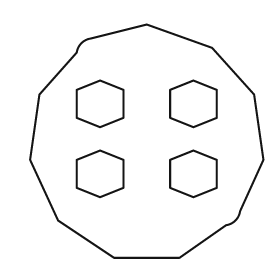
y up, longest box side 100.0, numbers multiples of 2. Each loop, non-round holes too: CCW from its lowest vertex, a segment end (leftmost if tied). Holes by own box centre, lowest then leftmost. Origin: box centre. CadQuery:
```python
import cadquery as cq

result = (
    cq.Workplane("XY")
    .moveTo(-14.0, -50.0)
    .lineTo(14.0, -50.0)
    .lineTo(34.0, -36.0)
    .threePointArc((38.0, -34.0), (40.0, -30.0))
    .lineTo(50.0, -8.0)
    .lineTo(46.0, 20.0)
    .lineTo(28.0, 40.0)
    .lineTo(0.0, 50.0)
    .lineTo(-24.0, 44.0)
    .threePointArc((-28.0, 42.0), (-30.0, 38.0))
    .lineTo(-46.0, 20.0)
    .lineTo(-50.0, -8.0)
    .lineTo(-38.0, -34.0)
    .close()
    .moveTo(-20.0, -24.0)
    .lineTo(-10.0, -20.0)
    .lineTo(-10.0, -8.0)
    .lineTo(-20.0, -4.0)
    .lineTo(-30.0, -8.0)
    .lineTo(-30.0, -20.0)
    .close()
    .moveTo(20.0, -24.0)
    .lineTo(30.0, -20.0)
    .lineTo(30.0, -8.0)
    .lineTo(20.0, -4.0)
    .lineTo(10.0, -8.0)
    .lineTo(10.0, -20.0)
    .close()
    .moveTo(-20.0, 6.0)
    .lineTo(-10.0, 10.0)
    .lineTo(-10.0, 22.0)
    .lineTo(-20.0, 26.0)
    .lineTo(-30.0, 22.0)
    .lineTo(-30.0, 10.0)
    .close()
    .moveTo(20.0, 6.0)
    .lineTo(30.0, 10.0)
    .lineTo(30.0, 22.0)
    .lineTo(20.0, 26.0)
    .lineTo(10.0, 22.0)
    .lineTo(10.0, 10.0)
    .close()
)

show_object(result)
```